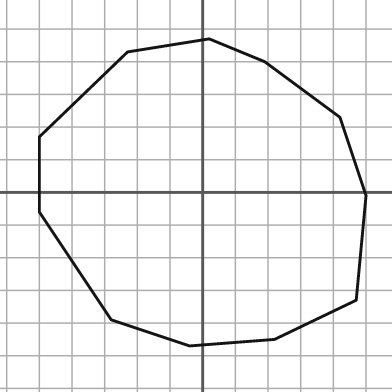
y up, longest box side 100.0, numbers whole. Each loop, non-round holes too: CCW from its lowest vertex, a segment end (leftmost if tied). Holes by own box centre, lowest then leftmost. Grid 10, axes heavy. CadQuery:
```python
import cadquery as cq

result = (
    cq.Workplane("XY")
    .moveTo(-4.0, -47.0)
    .lineTo(22.0, -45.0)
    .lineTo(47.0, -33.0)
    .lineTo(50.0, -1.0)
    .lineTo(42.0, 23.0)
    .lineTo(19.0, 40.0)
    .lineTo(2.0, 47.0)
    .lineTo(-23.0, 43.0)
    .lineTo(-50.0, 17.0)
    .lineTo(-50.0, -6.0)
    .lineTo(-28.0, -39.0)
    .close()
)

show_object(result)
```